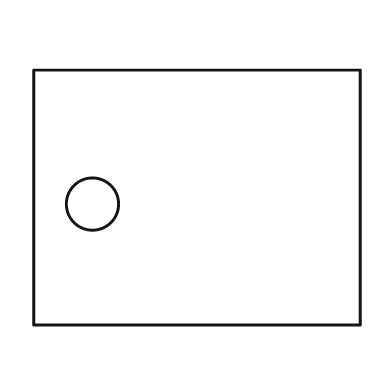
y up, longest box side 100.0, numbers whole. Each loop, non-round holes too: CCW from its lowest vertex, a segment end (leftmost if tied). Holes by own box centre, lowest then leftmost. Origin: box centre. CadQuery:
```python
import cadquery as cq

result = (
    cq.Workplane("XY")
    .moveTo(-50.0, -39.0)
    .lineTo(50.0, -39.0)
    .lineTo(50.0, 39.0)
    .lineTo(-50.0, 39.0)
    .close()
    .moveTo(-32.0, -2.0)
    .circle(8.0)
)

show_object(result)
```